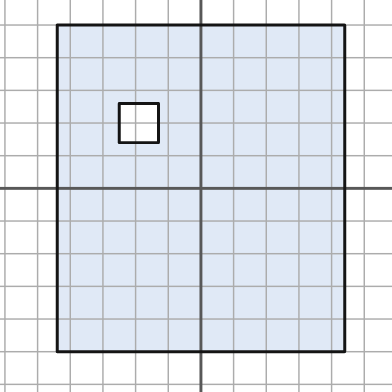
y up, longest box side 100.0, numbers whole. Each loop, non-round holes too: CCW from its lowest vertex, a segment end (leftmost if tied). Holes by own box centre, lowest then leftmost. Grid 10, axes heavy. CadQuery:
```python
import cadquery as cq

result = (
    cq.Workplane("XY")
    .moveTo(-44.0, -50.0)
    .lineTo(44.0, -50.0)
    .lineTo(44.0, 50.0)
    .lineTo(-44.0, 50.0)
    .close()
    .moveTo(-25.0, 14.0)
    .lineTo(-13.0, 14.0)
    .lineTo(-13.0, 26.0)
    .lineTo(-25.0, 26.0)
    .close()
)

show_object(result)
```